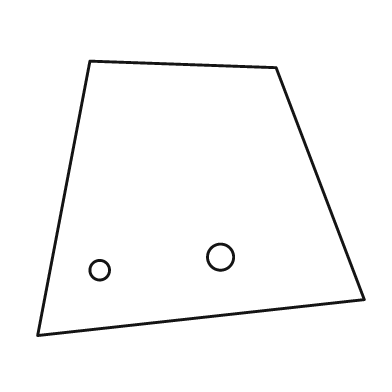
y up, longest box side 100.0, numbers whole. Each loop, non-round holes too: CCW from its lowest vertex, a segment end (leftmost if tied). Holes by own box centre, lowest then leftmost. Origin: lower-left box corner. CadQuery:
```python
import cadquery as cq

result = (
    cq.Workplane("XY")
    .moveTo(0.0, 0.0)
    .lineTo(100.0, 11.0)
    .lineTo(73.0, 82.0)
    .lineTo(16.0, 84.0)
    .close()
    .moveTo(19.0, 20.0)
    .circle(3.0)
    .moveTo(56.0, 24.0)
    .circle(4.0)
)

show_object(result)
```